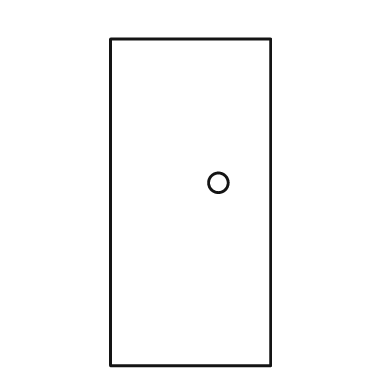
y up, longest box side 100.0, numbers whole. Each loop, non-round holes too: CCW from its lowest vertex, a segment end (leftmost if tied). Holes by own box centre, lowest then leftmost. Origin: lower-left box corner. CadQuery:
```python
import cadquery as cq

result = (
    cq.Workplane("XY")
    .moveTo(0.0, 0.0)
    .lineTo(49.0, 0.0)
    .lineTo(49.0, 100.0)
    .lineTo(0.0, 100.0)
    .close()
    .moveTo(33.0, 56.0)
    .circle(3.0)
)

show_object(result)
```